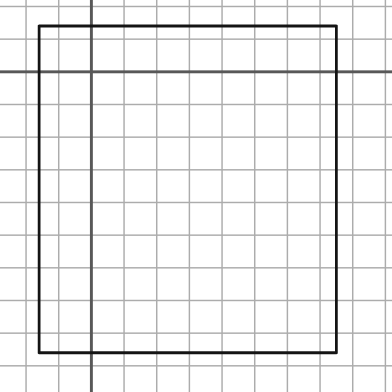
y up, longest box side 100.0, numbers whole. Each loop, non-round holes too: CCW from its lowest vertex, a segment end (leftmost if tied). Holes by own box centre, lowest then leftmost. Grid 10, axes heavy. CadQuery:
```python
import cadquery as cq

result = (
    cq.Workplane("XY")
    .moveTo(-16.0, -86.0)
    .lineTo(75.0, -86.0)
    .lineTo(75.0, 14.0)
    .lineTo(-16.0, 14.0)
    .close()
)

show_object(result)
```